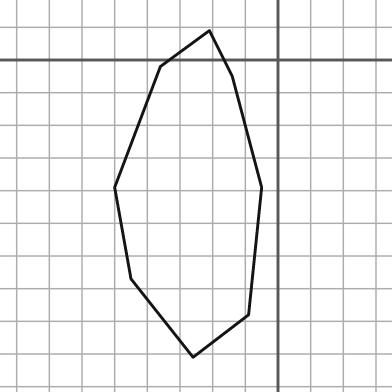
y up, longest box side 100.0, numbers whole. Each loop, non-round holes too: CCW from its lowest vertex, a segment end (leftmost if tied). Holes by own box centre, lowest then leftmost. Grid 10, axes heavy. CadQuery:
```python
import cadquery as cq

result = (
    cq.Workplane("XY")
    .moveTo(-26.0, -91.0)
    .lineTo(-9.0, -78.0)
    .lineTo(-5.0, -39.0)
    .lineTo(-14.0, -5.0)
    .lineTo(-21.0, 9.0)
    .lineTo(-36.0, -2.0)
    .lineTo(-50.0, -39.0)
    .lineTo(-45.0, -67.0)
    .close()
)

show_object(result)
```